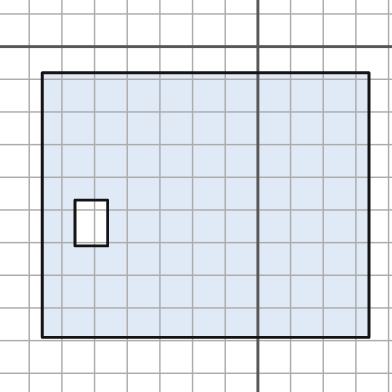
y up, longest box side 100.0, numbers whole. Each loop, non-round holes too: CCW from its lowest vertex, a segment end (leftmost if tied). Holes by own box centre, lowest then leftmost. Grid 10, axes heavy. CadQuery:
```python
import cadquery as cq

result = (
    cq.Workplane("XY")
    .moveTo(-66.0, -89.0)
    .lineTo(34.0, -89.0)
    .lineTo(34.0, -8.0)
    .lineTo(-66.0, -8.0)
    .close()
    .moveTo(-56.0, -61.0)
    .lineTo(-46.0, -61.0)
    .lineTo(-46.0, -47.0)
    .lineTo(-56.0, -47.0)
    .close()
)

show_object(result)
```